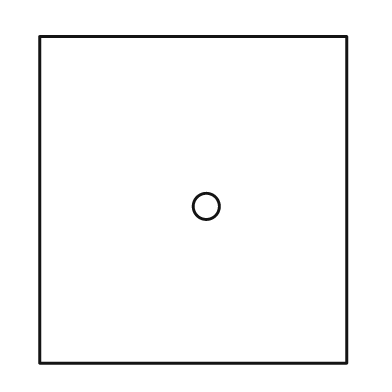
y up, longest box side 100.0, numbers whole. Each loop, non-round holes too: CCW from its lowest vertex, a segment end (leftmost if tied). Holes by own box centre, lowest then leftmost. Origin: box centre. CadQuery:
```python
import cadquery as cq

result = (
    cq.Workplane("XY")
    .moveTo(-47.0, -50.0)
    .lineTo(47.0, -50.0)
    .lineTo(47.0, 50.0)
    .lineTo(-47.0, 50.0)
    .close()
    .moveTo(4.0, -2.0)
    .circle(4.0)
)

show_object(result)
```